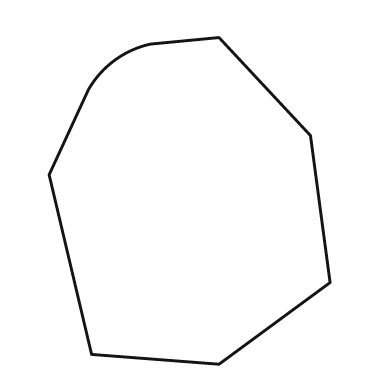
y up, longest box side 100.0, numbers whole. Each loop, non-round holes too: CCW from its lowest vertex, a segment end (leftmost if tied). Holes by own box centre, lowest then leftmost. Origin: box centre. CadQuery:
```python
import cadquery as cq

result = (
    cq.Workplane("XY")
    .moveTo(9.0, -50.0)
    .lineTo(43.0, -25.0)
    .lineTo(37.0, 20.0)
    .lineTo(9.0, 50.0)
    .lineTo(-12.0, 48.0)
    .threePointArc((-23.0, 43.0), (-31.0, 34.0))
    .lineTo(-43.0, 8.0)
    .lineTo(-30.0, -47.0)
    .close()
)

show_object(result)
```